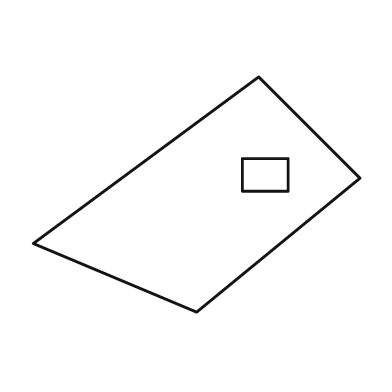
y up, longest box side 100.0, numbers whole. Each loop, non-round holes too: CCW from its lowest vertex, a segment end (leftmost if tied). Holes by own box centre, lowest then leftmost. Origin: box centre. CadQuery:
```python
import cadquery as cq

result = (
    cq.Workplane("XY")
    .moveTo(0.0, -36.0)
    .lineTo(50.0, 5.0)
    .lineTo(19.0, 36.0)
    .lineTo(-50.0, -15.0)
    .close()
    .moveTo(14.0, 1.0)
    .lineTo(28.0, 1.0)
    .lineTo(28.0, 11.0)
    .lineTo(14.0, 11.0)
    .close()
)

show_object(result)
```